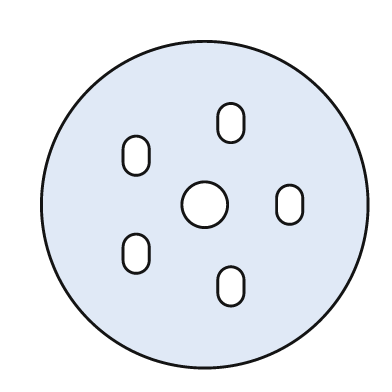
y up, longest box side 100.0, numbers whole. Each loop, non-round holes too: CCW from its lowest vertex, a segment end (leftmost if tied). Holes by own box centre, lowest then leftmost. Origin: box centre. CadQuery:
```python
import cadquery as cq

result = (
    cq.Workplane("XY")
    .moveTo(0.0, 0.0)
    .circle(50.0)
    .moveTo(4.0, -27.0)
    .threePointArc((8.0, -31.0), (12.0, -27.0))
    .lineTo(12.0, -23.0)
    .threePointArc((8.0, -19.0), (4.0, -23.0))
    .close()
    .moveTo(-25.0, -17.0)
    .threePointArc((-21.0, -21.0), (-17.0, -17.0))
    .lineTo(-17.0, -13.0)
    .threePointArc((-21.0, -9.0), (-25.0, -13.0))
    .close()
    .moveTo(0.0, 0.0)
    .circle(7.0)
    .moveTo(22.0, -2.0)
    .threePointArc((26.0, -6.0), (30.0, -2.0))
    .lineTo(30.0, 2.0)
    .threePointArc((26.0, 6.0), (22.0, 2.0))
    .close()
    .moveTo(-25.0, 13.0)
    .threePointArc((-21.0, 9.0), (-17.0, 13.0))
    .lineTo(-17.0, 17.0)
    .threePointArc((-21.0, 21.0), (-25.0, 17.0))
    .close()
    .moveTo(4.0, 23.0)
    .threePointArc((8.0, 19.0), (12.0, 23.0))
    .lineTo(12.0, 27.0)
    .threePointArc((8.0, 31.0), (4.0, 27.0))
    .close()
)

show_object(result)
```